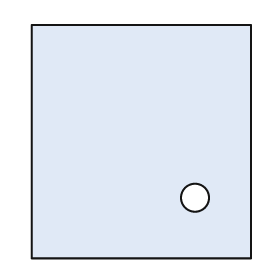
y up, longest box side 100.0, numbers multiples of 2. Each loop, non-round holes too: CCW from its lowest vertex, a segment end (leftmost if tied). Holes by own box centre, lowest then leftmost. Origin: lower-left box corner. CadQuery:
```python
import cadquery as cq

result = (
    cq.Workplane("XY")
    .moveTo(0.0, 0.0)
    .lineTo(94.0, 0.0)
    .lineTo(94.0, 100.0)
    .lineTo(0.0, 100.0)
    .close()
    .moveTo(70.0, 26.0)
    .circle(6.0)
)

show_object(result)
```